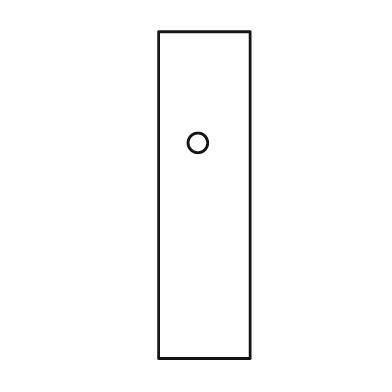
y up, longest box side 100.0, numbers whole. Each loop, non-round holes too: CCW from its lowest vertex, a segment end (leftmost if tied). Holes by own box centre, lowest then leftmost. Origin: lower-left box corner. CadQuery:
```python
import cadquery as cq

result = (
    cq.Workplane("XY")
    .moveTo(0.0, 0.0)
    .lineTo(28.0, 0.0)
    .lineTo(28.0, 100.0)
    .lineTo(0.0, 100.0)
    .close()
    .moveTo(12.0, 66.0)
    .circle(3.0)
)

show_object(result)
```